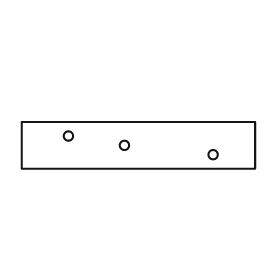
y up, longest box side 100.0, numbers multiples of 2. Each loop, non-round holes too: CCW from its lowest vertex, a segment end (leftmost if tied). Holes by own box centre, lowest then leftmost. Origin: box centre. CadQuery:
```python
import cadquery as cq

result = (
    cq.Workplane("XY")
    .moveTo(-50.0, -10.0)
    .lineTo(50.0, -10.0)
    .lineTo(50.0, 10.0)
    .lineTo(-50.0, 10.0)
    .close()
    .moveTo(32.0, -4.0)
    .circle(2.0)
    .moveTo(-6.0, 0.0)
    .circle(2.0)
    .moveTo(-30.0, 4.0)
    .circle(2.0)
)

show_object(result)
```